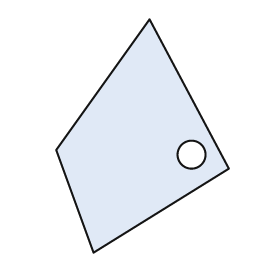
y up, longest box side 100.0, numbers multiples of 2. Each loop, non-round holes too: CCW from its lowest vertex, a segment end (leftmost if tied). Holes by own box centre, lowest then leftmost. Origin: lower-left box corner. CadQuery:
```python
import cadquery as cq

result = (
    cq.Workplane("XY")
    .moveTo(16.0, 0.0)
    .lineTo(74.0, 36.0)
    .lineTo(40.0, 100.0)
    .lineTo(0.0, 44.0)
    .close()
    .moveTo(58.0, 42.0)
    .circle(6.0)
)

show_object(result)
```